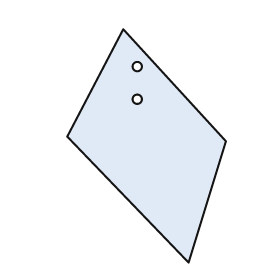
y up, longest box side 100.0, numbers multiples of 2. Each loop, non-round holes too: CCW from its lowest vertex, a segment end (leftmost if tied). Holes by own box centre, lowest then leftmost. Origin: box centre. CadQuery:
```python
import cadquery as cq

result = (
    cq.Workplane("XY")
    .moveTo(18.0, -50.0)
    .lineTo(34.0, 2.0)
    .lineTo(-10.0, 50.0)
    .lineTo(-34.0, 4.0)
    .close()
    .moveTo(-4.0, 20.0)
    .circle(2.0)
    .moveTo(-4.0, 34.0)
    .circle(2.0)
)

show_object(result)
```